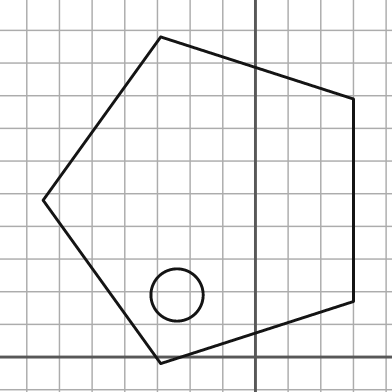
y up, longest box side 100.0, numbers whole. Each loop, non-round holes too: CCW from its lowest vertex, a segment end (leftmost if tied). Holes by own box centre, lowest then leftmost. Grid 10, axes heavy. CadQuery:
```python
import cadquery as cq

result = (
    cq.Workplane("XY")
    .moveTo(-29.0, -2.0)
    .lineTo(30.0, 17.0)
    .lineTo(30.0, 79.0)
    .lineTo(-29.0, 98.0)
    .lineTo(-65.0, 48.0)
    .close()
    .moveTo(-24.0, 19.0)
    .circle(8.0)
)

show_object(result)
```